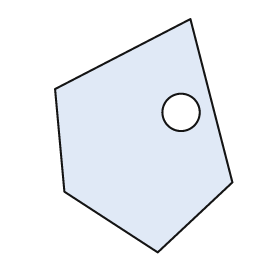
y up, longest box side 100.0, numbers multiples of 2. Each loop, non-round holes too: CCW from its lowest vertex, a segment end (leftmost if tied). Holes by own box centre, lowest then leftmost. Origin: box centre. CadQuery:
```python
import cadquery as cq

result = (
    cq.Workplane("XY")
    .moveTo(6.0, -50.0)
    .lineTo(38.0, -20.0)
    .lineTo(20.0, 50.0)
    .lineTo(-38.0, 20.0)
    .lineTo(-34.0, -24.0)
    .close()
    .moveTo(16.0, 10.0)
    .circle(8.0)
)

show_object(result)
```